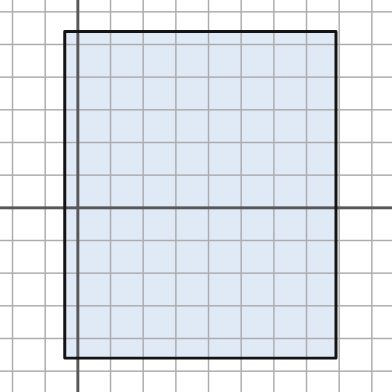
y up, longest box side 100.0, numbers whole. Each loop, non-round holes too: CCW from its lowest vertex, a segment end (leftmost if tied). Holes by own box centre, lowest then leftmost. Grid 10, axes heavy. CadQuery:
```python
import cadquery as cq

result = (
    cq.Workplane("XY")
    .moveTo(-4.0, -46.0)
    .lineTo(79.0, -46.0)
    .lineTo(79.0, 54.0)
    .lineTo(-4.0, 54.0)
    .close()
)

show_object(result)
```